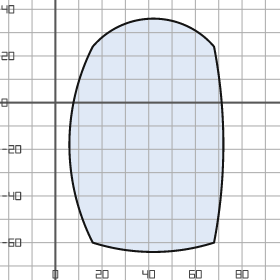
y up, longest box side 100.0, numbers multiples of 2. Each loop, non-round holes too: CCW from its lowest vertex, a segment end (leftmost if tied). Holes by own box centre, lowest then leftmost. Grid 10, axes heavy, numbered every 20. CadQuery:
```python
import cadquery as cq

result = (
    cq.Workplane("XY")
    .moveTo(16.0, -60.0)
    .threePointArc((42.0, -64.0), (68.0, -60.0))
    .threePointArc((72.0, -18.0), (68.0, 24.0))
    .threePointArc((42.0, 36.0), (16.0, 24.0))
    .threePointArc((6.0, -18.0), (16.0, -60.0))
    .close()
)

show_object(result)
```